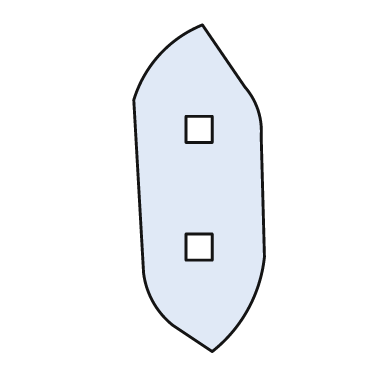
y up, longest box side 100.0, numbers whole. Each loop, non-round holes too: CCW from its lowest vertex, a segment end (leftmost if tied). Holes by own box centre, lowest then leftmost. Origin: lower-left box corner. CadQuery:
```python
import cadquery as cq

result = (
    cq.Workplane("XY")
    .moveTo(24.0, 0.0)
    .threePointArc((35.0, 13.0), (40.0, 29.0))
    .lineTo(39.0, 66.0)
    .threePointArc((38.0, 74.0), (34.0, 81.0))
    .lineTo(21.0, 100.0)
    .threePointArc((8.0, 91.0), (0.0, 77.0))
    .lineTo(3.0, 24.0)
    .threePointArc((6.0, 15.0), (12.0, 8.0))
    .close()
    .moveTo(16.0, 28.0)
    .lineTo(24.0, 28.0)
    .lineTo(24.0, 36.0)
    .lineTo(16.0, 36.0)
    .close()
    .moveTo(16.0, 64.0)
    .lineTo(24.0, 64.0)
    .lineTo(24.0, 72.0)
    .lineTo(16.0, 72.0)
    .close()
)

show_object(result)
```